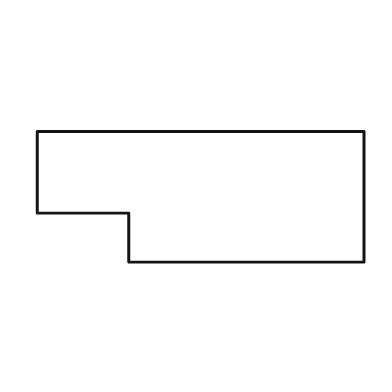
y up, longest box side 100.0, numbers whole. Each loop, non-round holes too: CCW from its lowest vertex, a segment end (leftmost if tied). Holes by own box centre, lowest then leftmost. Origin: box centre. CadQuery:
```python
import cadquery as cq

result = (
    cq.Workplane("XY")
    .moveTo(-22.0, -20.0)
    .lineTo(50.0, -20.0)
    .lineTo(50.0, 20.0)
    .lineTo(-50.0, 20.0)
    .lineTo(-50.0, -5.0)
    .lineTo(-22.0, -5.0)
    .close()
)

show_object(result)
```